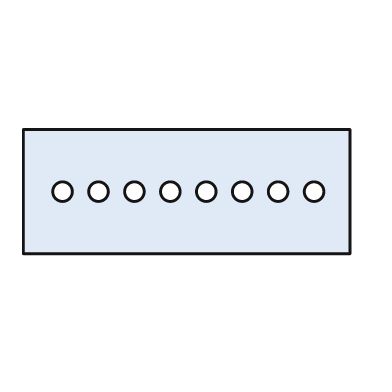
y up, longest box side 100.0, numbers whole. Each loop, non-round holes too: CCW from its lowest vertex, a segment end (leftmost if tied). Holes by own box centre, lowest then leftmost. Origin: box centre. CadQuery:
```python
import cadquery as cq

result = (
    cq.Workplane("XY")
    .moveTo(-50.0, -19.0)
    .lineTo(50.0, -19.0)
    .lineTo(50.0, 19.0)
    .lineTo(-50.0, 19.0)
    .close()
    .moveTo(-38.0, 0.0)
    .circle(3.0)
    .moveTo(-27.0, 0.0)
    .circle(3.0)
    .moveTo(-16.0, 0.0)
    .circle(3.0)
    .moveTo(-5.0, 0.0)
    .circle(3.0)
    .moveTo(6.0, 0.0)
    .circle(3.0)
    .moveTo(17.0, 0.0)
    .circle(3.0)
    .moveTo(28.0, 0.0)
    .circle(3.0)
    .moveTo(39.0, 0.0)
    .circle(3.0)
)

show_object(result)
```